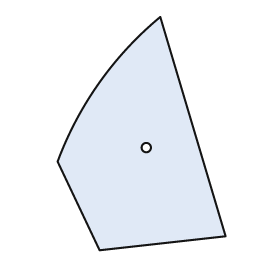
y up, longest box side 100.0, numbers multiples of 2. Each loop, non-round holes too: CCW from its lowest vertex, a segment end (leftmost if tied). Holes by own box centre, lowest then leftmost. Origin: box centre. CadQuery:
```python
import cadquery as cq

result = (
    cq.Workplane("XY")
    .moveTo(-18.0, -50.0)
    .lineTo(36.0, -44.0)
    .lineTo(8.0, 50.0)
    .threePointArc((-18.0, 22.0), (-36.0, -12.0))
    .close()
    .moveTo(2.0, -6.0)
    .circle(2.0)
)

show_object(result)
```